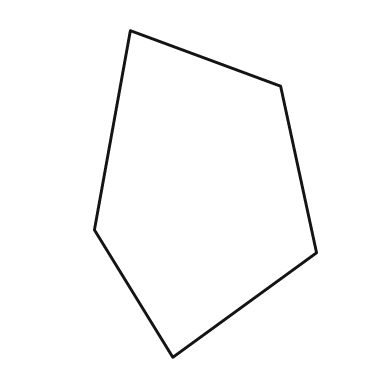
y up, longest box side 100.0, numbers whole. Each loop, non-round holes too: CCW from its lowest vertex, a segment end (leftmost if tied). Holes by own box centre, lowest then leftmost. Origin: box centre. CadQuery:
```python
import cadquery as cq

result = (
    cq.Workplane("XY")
    .moveTo(-10.0, -50.0)
    .lineTo(34.0, -18.0)
    .lineTo(23.0, 33.0)
    .lineTo(-23.0, 50.0)
    .lineTo(-34.0, -11.0)
    .close()
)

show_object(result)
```